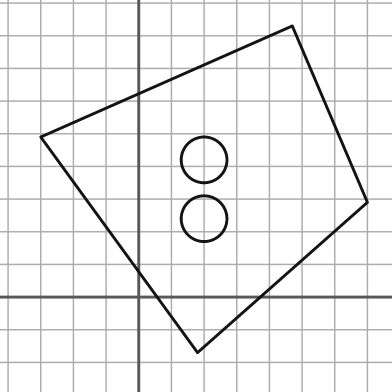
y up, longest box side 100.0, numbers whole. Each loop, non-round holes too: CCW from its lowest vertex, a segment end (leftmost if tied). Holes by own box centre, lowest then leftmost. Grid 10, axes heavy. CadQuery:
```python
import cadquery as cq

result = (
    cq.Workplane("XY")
    .moveTo(18.0, -17.0)
    .lineTo(70.0, 29.0)
    .lineTo(47.0, 83.0)
    .lineTo(-30.0, 49.0)
    .close()
    .moveTo(20.0, 24.0)
    .circle(7.0)
    .moveTo(20.0, 42.0)
    .circle(7.0)
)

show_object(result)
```